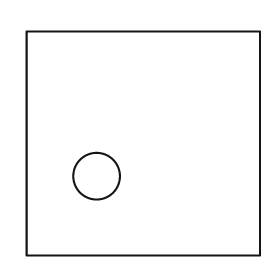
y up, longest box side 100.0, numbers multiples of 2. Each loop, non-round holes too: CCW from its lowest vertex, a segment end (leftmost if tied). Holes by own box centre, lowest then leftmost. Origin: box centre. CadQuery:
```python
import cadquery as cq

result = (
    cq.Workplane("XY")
    .moveTo(-50.0, -48.0)
    .lineTo(50.0, -48.0)
    .lineTo(50.0, 48.0)
    .lineTo(-50.0, 48.0)
    .close()
    .moveTo(-20.0, -14.0)
    .circle(10.0)
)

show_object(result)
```